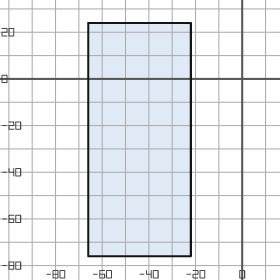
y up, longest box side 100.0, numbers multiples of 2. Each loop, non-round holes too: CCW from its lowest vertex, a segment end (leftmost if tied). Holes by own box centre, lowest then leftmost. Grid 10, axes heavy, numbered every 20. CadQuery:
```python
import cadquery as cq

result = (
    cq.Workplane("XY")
    .moveTo(-66.0, -76.0)
    .lineTo(-22.0, -76.0)
    .lineTo(-22.0, 24.0)
    .lineTo(-66.0, 24.0)
    .close()
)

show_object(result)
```